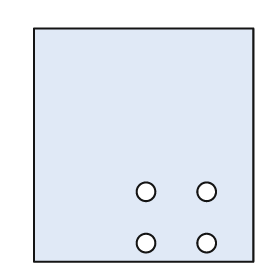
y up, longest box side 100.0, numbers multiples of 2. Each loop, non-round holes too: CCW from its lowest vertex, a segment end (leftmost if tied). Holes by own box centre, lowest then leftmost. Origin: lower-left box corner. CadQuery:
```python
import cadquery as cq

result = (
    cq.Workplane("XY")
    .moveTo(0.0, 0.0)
    .lineTo(94.0, 0.0)
    .lineTo(94.0, 100.0)
    .lineTo(0.0, 100.0)
    .close()
    .moveTo(48.0, 8.0)
    .circle(4.0)
    .moveTo(74.0, 8.0)
    .circle(4.0)
    .moveTo(48.0, 30.0)
    .circle(4.0)
    .moveTo(74.0, 30.0)
    .circle(4.0)
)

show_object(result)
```